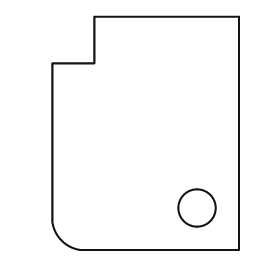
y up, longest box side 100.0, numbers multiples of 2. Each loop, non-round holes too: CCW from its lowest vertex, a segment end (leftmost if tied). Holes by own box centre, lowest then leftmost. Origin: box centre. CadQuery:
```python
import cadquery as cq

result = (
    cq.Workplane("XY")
    .moveTo(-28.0, -50.0)
    .lineTo(40.0, -50.0)
    .lineTo(40.0, 50.0)
    .lineTo(-22.0, 50.0)
    .lineTo(-22.0, 30.0)
    .lineTo(-40.0, 30.0)
    .lineTo(-40.0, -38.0)
    .threePointArc((-36.0, -46.0), (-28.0, -50.0))
    .close()
    .moveTo(22.0, -32.0)
    .circle(8.0)
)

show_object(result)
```